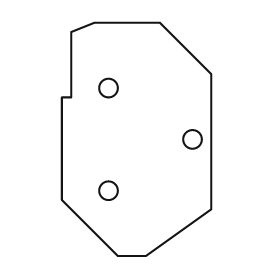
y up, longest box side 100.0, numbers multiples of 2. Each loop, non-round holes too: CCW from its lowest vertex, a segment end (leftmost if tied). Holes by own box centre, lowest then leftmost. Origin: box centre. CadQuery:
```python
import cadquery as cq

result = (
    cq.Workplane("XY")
    .moveTo(-8.0, -50.0)
    .lineTo(4.0, -50.0)
    .lineTo(32.0, -30.0)
    .lineTo(32.0, 28.0)
    .lineTo(10.0, 50.0)
    .lineTo(-18.0, 50.0)
    .lineTo(-28.0, 46.0)
    .lineTo(-28.0, 18.0)
    .lineTo(-32.0, 18.0)
    .lineTo(-32.0, -26.0)
    .close()
    .moveTo(-12.0, -22.0)
    .circle(4.0)
    .moveTo(24.0, 0.0)
    .circle(4.0)
    .moveTo(-12.0, 22.0)
    .circle(4.0)
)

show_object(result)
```